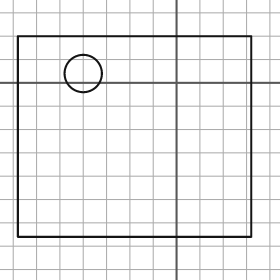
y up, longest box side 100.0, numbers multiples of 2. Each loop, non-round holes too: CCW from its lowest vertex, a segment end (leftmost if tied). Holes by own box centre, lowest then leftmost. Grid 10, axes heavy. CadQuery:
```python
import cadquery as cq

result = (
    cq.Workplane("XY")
    .moveTo(-68.0, -66.0)
    .lineTo(32.0, -66.0)
    .lineTo(32.0, 20.0)
    .lineTo(-68.0, 20.0)
    .close()
    .moveTo(-40.0, 4.0)
    .circle(8.0)
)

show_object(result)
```